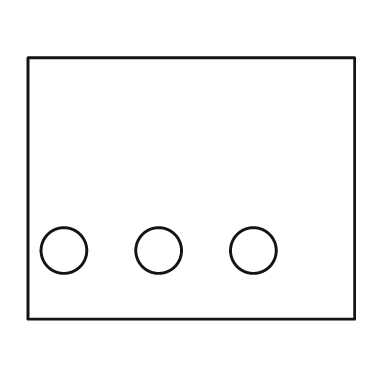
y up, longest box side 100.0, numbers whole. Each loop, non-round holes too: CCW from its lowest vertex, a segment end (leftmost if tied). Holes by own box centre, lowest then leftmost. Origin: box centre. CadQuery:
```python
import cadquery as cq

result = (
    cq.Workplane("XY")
    .moveTo(-50.0, -40.0)
    .lineTo(50.0, -40.0)
    .lineTo(50.0, 40.0)
    .lineTo(-50.0, 40.0)
    .close()
    .moveTo(-39.0, -19.0)
    .circle(7.0)
    .moveTo(-10.0, -19.0)
    .circle(7.0)
    .moveTo(19.0, -19.0)
    .circle(7.0)
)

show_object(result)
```